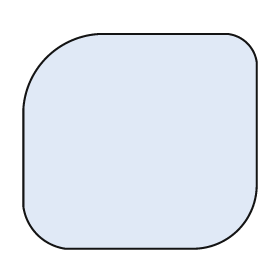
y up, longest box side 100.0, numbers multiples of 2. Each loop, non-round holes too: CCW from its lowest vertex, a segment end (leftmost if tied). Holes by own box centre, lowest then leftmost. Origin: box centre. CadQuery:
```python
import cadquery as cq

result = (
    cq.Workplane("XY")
    .moveTo(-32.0, -46.0)
    .lineTo(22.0, -46.0)
    .threePointArc((42.0, -38.0), (50.0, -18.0))
    .lineTo(50.0, 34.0)
    .threePointArc((46.0, 42.0), (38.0, 46.0))
    .lineTo(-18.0, 46.0)
    .threePointArc((-40.0, 36.0), (-50.0, 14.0))
    .lineTo(-50.0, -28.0)
    .threePointArc((-44.0, -40.0), (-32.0, -46.0))
    .close()
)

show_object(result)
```